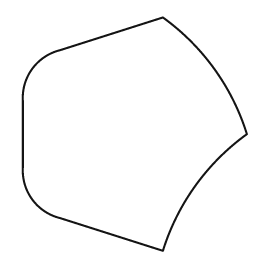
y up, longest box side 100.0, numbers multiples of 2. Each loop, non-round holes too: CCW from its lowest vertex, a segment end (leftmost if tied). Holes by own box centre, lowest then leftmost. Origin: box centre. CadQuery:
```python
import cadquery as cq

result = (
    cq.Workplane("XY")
    .moveTo(12.0, -50.0)
    .threePointArc((26.0, -22.0), (48.0, 0.0))
    .threePointArc((34.0, 28.0), (12.0, 50.0))
    .lineTo(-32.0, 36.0)
    .threePointArc((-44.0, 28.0), (-48.0, 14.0))
    .lineTo(-48.0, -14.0)
    .threePointArc((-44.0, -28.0), (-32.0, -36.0))
    .close()
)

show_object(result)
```